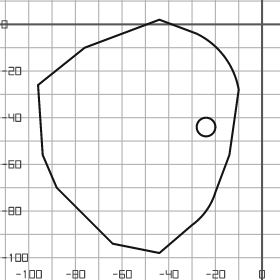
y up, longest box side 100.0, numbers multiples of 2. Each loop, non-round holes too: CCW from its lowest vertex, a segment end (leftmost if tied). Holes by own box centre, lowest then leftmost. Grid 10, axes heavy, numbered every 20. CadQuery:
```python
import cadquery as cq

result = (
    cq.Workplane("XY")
    .moveTo(-44.0, -98.0)
    .lineTo(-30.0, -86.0)
    .threePointArc((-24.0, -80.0), (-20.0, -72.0))
    .lineTo(-14.0, -56.0)
    .lineTo(-10.0, -28.0)
    .threePointArc((-16.0, -14.0), (-28.0, -4.0))
    .lineTo(-44.0, 2.0)
    .lineTo(-76.0, -10.0)
    .lineTo(-96.0, -26.0)
    .lineTo(-94.0, -56.0)
    .lineTo(-88.0, -70.0)
    .lineTo(-64.0, -94.0)
    .close()
    .moveTo(-24.0, -44.0)
    .circle(4.0)
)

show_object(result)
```